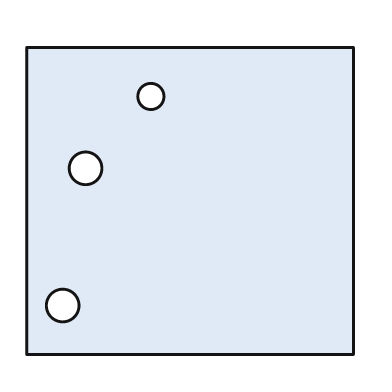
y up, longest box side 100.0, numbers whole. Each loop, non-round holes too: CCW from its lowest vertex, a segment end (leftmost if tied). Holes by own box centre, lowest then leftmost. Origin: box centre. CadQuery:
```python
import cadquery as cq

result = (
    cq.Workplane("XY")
    .moveTo(-50.0, -47.0)
    .lineTo(50.0, -47.0)
    .lineTo(50.0, 47.0)
    .lineTo(-50.0, 47.0)
    .close()
    .moveTo(-39.0, -32.0)
    .circle(5.0)
    .moveTo(-32.0, 10.0)
    .circle(5.0)
    .moveTo(-12.0, 32.0)
    .circle(4.0)
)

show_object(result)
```